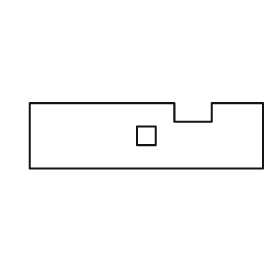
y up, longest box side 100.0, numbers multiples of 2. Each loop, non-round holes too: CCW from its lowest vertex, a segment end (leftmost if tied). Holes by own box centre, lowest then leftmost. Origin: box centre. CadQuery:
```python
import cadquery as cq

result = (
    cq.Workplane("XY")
    .moveTo(-50.0, -14.0)
    .lineTo(50.0, -14.0)
    .lineTo(50.0, 14.0)
    .lineTo(28.0, 14.0)
    .lineTo(28.0, 6.0)
    .lineTo(12.0, 6.0)
    .lineTo(12.0, 14.0)
    .lineTo(-50.0, 14.0)
    .close()
    .moveTo(-4.0, -4.0)
    .lineTo(4.0, -4.0)
    .lineTo(4.0, 4.0)
    .lineTo(-4.0, 4.0)
    .close()
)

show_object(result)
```